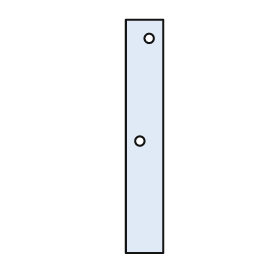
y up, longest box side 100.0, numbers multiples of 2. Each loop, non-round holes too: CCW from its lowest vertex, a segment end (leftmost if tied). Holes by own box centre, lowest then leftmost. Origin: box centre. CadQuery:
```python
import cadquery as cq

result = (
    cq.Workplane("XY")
    .moveTo(-8.0, -50.0)
    .lineTo(8.0, -50.0)
    .lineTo(8.0, 50.0)
    .lineTo(-8.0, 50.0)
    .close()
    .moveTo(-2.0, -2.0)
    .circle(2.0)
    .moveTo(2.0, 42.0)
    .circle(2.0)
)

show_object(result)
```